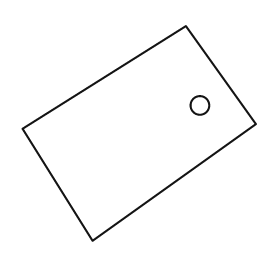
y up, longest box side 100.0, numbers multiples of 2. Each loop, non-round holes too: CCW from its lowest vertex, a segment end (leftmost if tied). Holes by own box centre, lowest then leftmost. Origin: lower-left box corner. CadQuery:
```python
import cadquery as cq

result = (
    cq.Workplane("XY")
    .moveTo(30.0, 0.0)
    .lineTo(100.0, 50.0)
    .lineTo(70.0, 92.0)
    .lineTo(0.0, 48.0)
    .close()
    .moveTo(76.0, 58.0)
    .circle(4.0)
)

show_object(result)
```